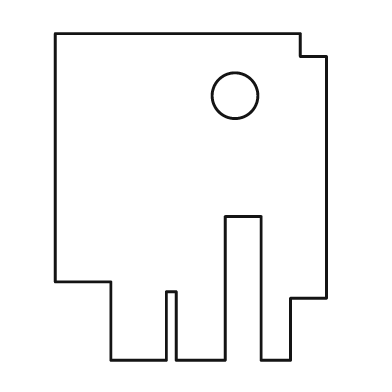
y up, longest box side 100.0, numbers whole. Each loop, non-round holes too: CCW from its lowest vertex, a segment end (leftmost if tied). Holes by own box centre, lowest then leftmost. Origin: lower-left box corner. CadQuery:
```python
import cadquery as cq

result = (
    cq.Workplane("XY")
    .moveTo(17.0, 0.0)
    .lineTo(34.0, 0.0)
    .lineTo(34.0, 21.0)
    .lineTo(37.0, 21.0)
    .lineTo(37.0, 0.0)
    .lineTo(52.0, 0.0)
    .lineTo(52.0, 44.0)
    .lineTo(63.0, 44.0)
    .lineTo(63.0, 0.0)
    .lineTo(72.0, 0.0)
    .lineTo(72.0, 19.0)
    .lineTo(83.0, 19.0)
    .lineTo(83.0, 93.0)
    .lineTo(75.0, 93.0)
    .lineTo(75.0, 100.0)
    .lineTo(0.0, 100.0)
    .lineTo(0.0, 24.0)
    .lineTo(17.0, 24.0)
    .close()
    .moveTo(55.0, 81.0)
    .circle(7.0)
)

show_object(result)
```